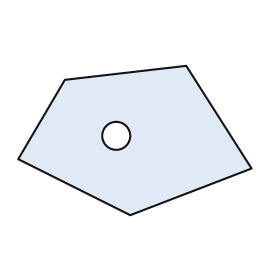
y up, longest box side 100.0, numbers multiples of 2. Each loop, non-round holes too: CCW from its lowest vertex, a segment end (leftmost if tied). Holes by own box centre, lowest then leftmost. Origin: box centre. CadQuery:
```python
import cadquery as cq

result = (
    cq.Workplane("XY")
    .moveTo(-2.0, -32.0)
    .lineTo(50.0, -12.0)
    .lineTo(22.0, 32.0)
    .lineTo(-30.0, 26.0)
    .lineTo(-50.0, -8.0)
    .close()
    .moveTo(-8.0, 2.0)
    .circle(6.0)
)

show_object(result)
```